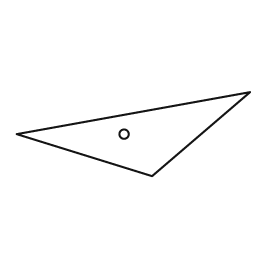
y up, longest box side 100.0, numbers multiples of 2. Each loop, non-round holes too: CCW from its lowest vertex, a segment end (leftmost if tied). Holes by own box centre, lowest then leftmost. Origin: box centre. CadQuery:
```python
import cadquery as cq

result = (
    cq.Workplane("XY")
    .moveTo(8.0, -18.0)
    .lineTo(50.0, 18.0)
    .lineTo(-50.0, 0.0)
    .close()
    .moveTo(-4.0, 0.0)
    .circle(2.0)
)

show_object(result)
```